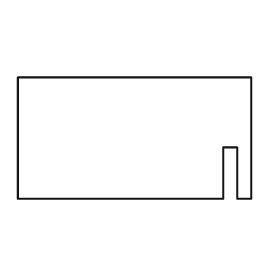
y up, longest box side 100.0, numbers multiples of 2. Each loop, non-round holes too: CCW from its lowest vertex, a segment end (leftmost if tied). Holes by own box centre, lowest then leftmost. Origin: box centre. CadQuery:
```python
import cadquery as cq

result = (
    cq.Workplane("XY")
    .moveTo(-50.0, -26.0)
    .lineTo(38.0, -26.0)
    .lineTo(38.0, -4.0)
    .lineTo(44.0, -4.0)
    .lineTo(44.0, -26.0)
    .lineTo(50.0, -26.0)
    .lineTo(50.0, 26.0)
    .lineTo(-50.0, 26.0)
    .close()
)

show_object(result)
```